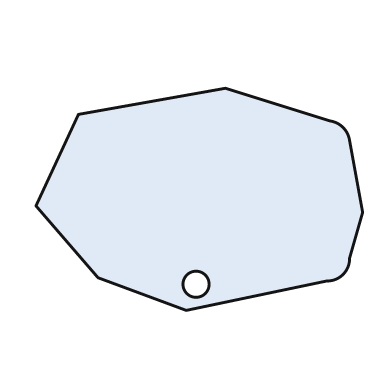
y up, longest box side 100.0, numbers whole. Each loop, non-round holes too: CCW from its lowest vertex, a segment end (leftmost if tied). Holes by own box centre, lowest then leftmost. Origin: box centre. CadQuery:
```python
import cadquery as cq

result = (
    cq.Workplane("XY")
    .moveTo(-4.0, -34.0)
    .lineTo(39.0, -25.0)
    .threePointArc((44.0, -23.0), (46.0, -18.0))
    .lineTo(50.0, -4.0)
    .lineTo(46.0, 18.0)
    .threePointArc((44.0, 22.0), (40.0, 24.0))
    .lineTo(8.0, 34.0)
    .lineTo(-37.0, 26.0)
    .lineTo(-50.0, -2.0)
    .lineTo(-31.0, -24.0)
    .close()
    .moveTo(-1.0, -26.0)
    .circle(4.0)
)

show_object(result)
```